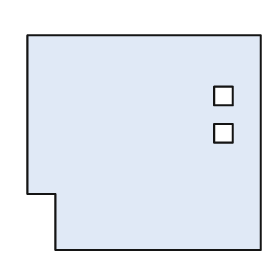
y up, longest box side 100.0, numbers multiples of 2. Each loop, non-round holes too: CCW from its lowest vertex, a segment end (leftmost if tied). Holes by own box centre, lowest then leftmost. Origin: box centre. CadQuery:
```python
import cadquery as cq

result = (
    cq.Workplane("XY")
    .moveTo(-38.0, -46.0)
    .lineTo(50.0, -46.0)
    .lineTo(50.0, 46.0)
    .lineTo(-50.0, 46.0)
    .lineTo(-50.0, -22.0)
    .lineTo(-38.0, -22.0)
    .close()
    .moveTo(30.0, 0.0)
    .lineTo(38.0, 0.0)
    .lineTo(38.0, 8.0)
    .lineTo(30.0, 8.0)
    .close()
    .moveTo(30.0, 16.0)
    .lineTo(38.0, 16.0)
    .lineTo(38.0, 24.0)
    .lineTo(30.0, 24.0)
    .close()
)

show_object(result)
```